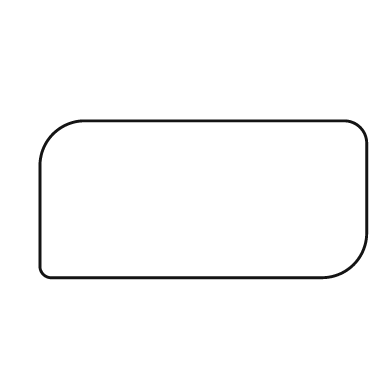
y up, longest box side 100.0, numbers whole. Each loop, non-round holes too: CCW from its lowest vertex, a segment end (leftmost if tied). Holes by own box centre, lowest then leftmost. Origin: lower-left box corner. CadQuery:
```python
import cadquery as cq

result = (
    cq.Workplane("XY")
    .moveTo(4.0, 0.0)
    .lineTo(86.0, 0.0)
    .threePointArc((96.0, 4.0), (100.0, 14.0))
    .lineTo(100.0, 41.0)
    .threePointArc((98.0, 46.0), (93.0, 48.0))
    .lineTo(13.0, 48.0)
    .threePointArc((4.0, 44.0), (0.0, 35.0))
    .lineTo(0.0, 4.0)
    .threePointArc((1.0, 1.0), (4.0, 0.0))
    .close()
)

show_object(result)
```